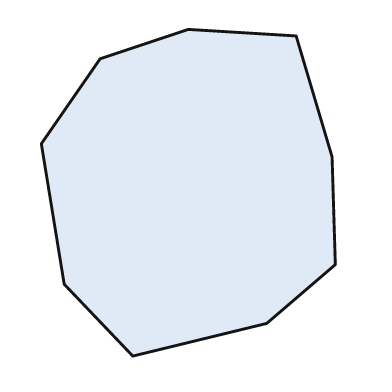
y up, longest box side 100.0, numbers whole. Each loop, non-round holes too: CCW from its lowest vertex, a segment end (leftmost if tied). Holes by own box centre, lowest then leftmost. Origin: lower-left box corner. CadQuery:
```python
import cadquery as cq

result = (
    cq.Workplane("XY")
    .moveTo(28.0, 0.0)
    .lineTo(69.0, 10.0)
    .lineTo(90.0, 28.0)
    .lineTo(89.0, 61.0)
    .lineTo(78.0, 98.0)
    .lineTo(45.0, 100.0)
    .lineTo(18.0, 91.0)
    .lineTo(0.0, 65.0)
    .lineTo(7.0, 22.0)
    .close()
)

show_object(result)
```